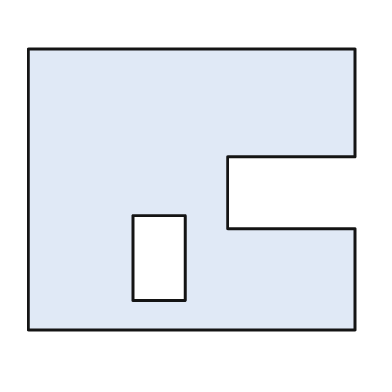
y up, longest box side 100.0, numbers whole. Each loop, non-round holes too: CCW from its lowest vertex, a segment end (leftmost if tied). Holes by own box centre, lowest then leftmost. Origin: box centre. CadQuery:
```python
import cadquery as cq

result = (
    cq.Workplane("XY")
    .moveTo(-50.0, -43.0)
    .lineTo(50.0, -43.0)
    .lineTo(50.0, -12.0)
    .lineTo(11.0, -12.0)
    .lineTo(11.0, 10.0)
    .lineTo(50.0, 10.0)
    .lineTo(50.0, 43.0)
    .lineTo(-50.0, 43.0)
    .close()
    .moveTo(-18.0, -34.0)
    .lineTo(-2.0, -34.0)
    .lineTo(-2.0, -8.0)
    .lineTo(-18.0, -8.0)
    .close()
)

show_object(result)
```